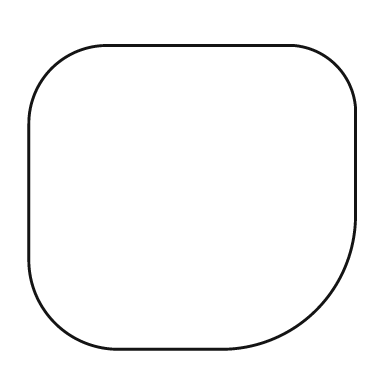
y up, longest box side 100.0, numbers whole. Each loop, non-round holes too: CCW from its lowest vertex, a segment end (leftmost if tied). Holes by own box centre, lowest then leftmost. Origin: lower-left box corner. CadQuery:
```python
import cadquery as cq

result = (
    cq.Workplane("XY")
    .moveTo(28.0, 0.0)
    .lineTo(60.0, 0.0)
    .threePointArc((88.0, 12.0), (100.0, 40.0))
    .lineTo(100.0, 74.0)
    .threePointArc((94.0, 87.0), (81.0, 93.0))
    .lineTo(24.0, 93.0)
    .threePointArc((7.0, 86.0), (0.0, 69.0))
    .lineTo(0.0, 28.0)
    .threePointArc((8.0, 8.0), (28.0, 0.0))
    .close()
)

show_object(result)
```